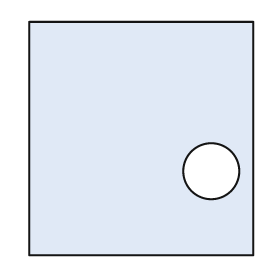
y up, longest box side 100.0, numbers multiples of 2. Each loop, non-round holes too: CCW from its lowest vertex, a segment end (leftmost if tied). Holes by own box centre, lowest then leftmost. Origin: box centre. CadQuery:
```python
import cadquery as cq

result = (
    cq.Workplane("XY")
    .moveTo(-48.0, -50.0)
    .lineTo(48.0, -50.0)
    .lineTo(48.0, 50.0)
    .lineTo(-48.0, 50.0)
    .close()
    .moveTo(30.0, -14.0)
    .circle(12.0)
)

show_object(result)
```